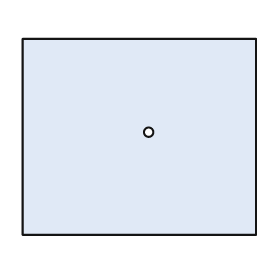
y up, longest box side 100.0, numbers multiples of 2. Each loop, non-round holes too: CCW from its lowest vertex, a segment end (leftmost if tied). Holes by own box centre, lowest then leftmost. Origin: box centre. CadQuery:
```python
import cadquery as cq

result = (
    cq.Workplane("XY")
    .moveTo(-50.0, -42.0)
    .lineTo(50.0, -42.0)
    .lineTo(50.0, 42.0)
    .lineTo(-50.0, 42.0)
    .close()
    .moveTo(4.0, 2.0)
    .circle(2.0)
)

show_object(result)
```